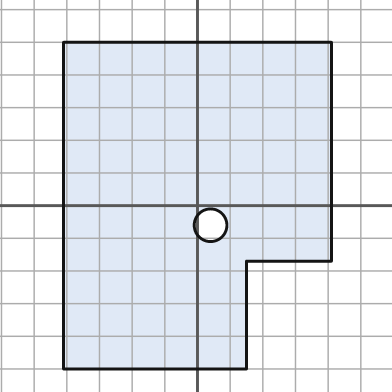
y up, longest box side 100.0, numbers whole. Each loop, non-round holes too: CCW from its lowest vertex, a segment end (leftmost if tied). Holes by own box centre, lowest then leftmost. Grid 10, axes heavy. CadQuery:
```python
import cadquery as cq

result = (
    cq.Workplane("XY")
    .moveTo(-41.0, -50.0)
    .lineTo(15.0, -50.0)
    .lineTo(15.0, -17.0)
    .lineTo(41.0, -17.0)
    .lineTo(41.0, 50.0)
    .lineTo(-41.0, 50.0)
    .close()
    .moveTo(4.0, -6.0)
    .circle(5.0)
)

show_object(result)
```